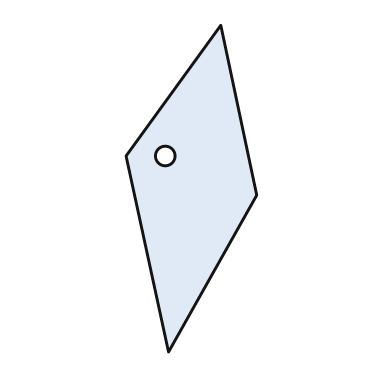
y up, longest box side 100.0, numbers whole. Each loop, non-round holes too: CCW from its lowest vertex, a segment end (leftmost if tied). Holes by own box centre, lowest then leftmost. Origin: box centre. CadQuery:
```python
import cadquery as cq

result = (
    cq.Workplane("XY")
    .moveTo(-7.0, -50.0)
    .lineTo(20.0, -2.0)
    .lineTo(9.0, 50.0)
    .lineTo(-20.0, 10.0)
    .close()
    .moveTo(-8.0, 10.0)
    .circle(3.0)
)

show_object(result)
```